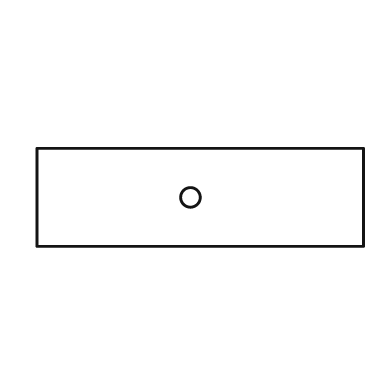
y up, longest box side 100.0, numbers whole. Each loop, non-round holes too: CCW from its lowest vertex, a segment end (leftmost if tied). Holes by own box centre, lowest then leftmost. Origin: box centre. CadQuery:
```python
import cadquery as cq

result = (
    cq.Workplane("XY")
    .moveTo(-50.0, -15.0)
    .lineTo(50.0, -15.0)
    .lineTo(50.0, 15.0)
    .lineTo(-50.0, 15.0)
    .close()
    .moveTo(-3.0, 0.0)
    .circle(3.0)
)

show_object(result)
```